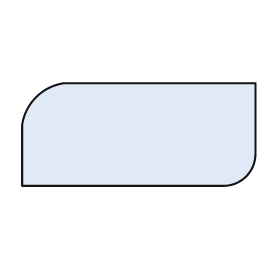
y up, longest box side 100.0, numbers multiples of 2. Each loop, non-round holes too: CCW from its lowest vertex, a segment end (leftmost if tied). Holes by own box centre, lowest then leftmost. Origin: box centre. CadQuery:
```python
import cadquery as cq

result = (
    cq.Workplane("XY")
    .moveTo(-50.0, -22.0)
    .lineTo(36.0, -22.0)
    .threePointArc((46.0, -18.0), (50.0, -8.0))
    .lineTo(50.0, 22.0)
    .lineTo(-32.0, 22.0)
    .threePointArc((-44.0, 16.0), (-50.0, 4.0))
    .close()
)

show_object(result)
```